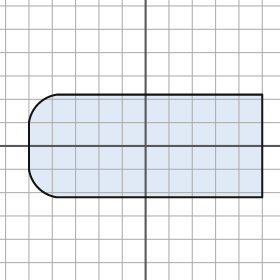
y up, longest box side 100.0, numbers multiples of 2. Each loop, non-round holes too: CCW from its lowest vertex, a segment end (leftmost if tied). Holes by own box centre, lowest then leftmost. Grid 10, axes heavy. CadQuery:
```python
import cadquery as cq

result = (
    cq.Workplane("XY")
    .moveTo(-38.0, -22.0)
    .lineTo(50.0, -22.0)
    .lineTo(50.0, 22.0)
    .lineTo(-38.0, 22.0)
    .threePointArc((-46.0, 18.0), (-50.0, 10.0))
    .lineTo(-50.0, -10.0)
    .threePointArc((-46.0, -18.0), (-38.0, -22.0))
    .close()
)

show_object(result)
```